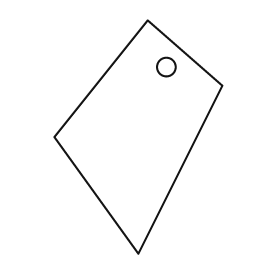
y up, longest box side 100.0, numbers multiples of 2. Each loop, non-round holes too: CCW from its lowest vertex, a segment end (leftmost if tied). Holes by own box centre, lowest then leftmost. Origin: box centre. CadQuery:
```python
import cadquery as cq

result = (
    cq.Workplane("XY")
    .moveTo(0.0, -50.0)
    .lineTo(36.0, 22.0)
    .lineTo(4.0, 50.0)
    .lineTo(-36.0, 0.0)
    .close()
    .moveTo(12.0, 30.0)
    .circle(4.0)
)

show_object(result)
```